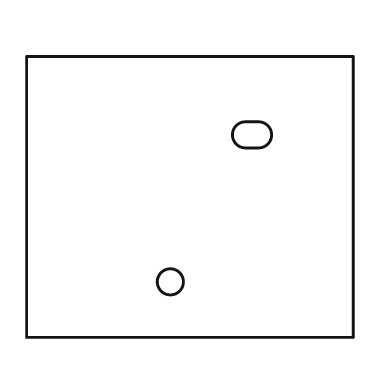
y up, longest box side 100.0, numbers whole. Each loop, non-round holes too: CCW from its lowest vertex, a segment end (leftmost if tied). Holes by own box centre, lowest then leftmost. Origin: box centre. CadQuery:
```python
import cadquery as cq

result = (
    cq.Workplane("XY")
    .moveTo(-50.0, -43.0)
    .lineTo(50.0, -43.0)
    .lineTo(50.0, 43.0)
    .lineTo(-50.0, 43.0)
    .close()
    .moveTo(-6.0, -26.0)
    .circle(4.0)
    .moveTo(17.0, 15.0)
    .lineTo(21.0, 15.0)
    .threePointArc((25.0, 19.0), (21.0, 23.0))
    .lineTo(17.0, 23.0)
    .threePointArc((13.0, 19.0), (17.0, 15.0))
    .close()
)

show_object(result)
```